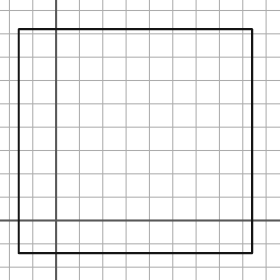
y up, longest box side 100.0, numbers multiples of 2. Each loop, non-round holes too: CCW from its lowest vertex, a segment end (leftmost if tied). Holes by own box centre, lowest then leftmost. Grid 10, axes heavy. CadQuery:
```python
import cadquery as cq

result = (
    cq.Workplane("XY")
    .moveTo(-16.0, -14.0)
    .lineTo(84.0, -14.0)
    .lineTo(84.0, 82.0)
    .lineTo(-16.0, 82.0)
    .close()
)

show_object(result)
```